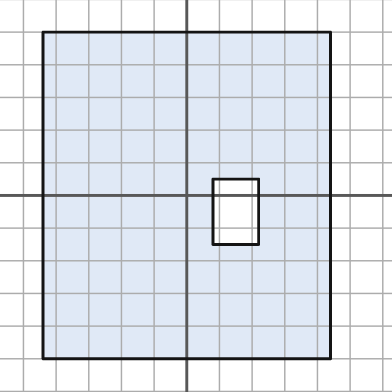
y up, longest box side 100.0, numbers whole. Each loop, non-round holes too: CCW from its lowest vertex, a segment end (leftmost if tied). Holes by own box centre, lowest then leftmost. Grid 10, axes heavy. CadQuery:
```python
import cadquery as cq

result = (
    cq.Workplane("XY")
    .moveTo(-44.0, -50.0)
    .lineTo(44.0, -50.0)
    .lineTo(44.0, 50.0)
    .lineTo(-44.0, 50.0)
    .close()
    .moveTo(8.0, -15.0)
    .lineTo(22.0, -15.0)
    .lineTo(22.0, 5.0)
    .lineTo(8.0, 5.0)
    .close()
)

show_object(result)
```